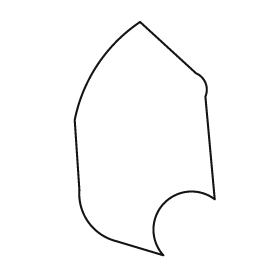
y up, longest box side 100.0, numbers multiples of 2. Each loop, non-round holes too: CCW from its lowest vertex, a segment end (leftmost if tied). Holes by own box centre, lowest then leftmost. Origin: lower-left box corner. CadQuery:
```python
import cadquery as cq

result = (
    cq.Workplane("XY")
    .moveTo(38.0, 0.0)
    .threePointArc((38.0, 22.0), (60.0, 24.0))
    .lineTo(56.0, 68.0)
    .threePointArc((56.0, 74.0), (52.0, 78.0))
    .lineTo(28.0, 100.0)
    .threePointArc((10.0, 82.0), (0.0, 58.0))
    .lineTo(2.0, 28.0)
    .threePointArc((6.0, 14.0), (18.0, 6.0))
    .close()
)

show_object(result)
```